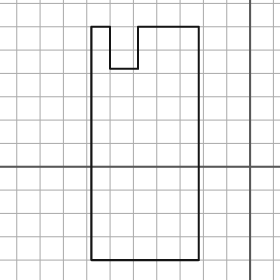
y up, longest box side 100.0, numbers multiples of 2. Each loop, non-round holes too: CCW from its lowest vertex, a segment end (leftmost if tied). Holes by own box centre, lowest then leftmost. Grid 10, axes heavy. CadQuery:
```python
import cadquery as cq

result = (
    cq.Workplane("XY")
    .moveTo(-68.0, -40.0)
    .lineTo(-22.0, -40.0)
    .lineTo(-22.0, 60.0)
    .lineTo(-48.0, 60.0)
    .lineTo(-48.0, 42.0)
    .lineTo(-60.0, 42.0)
    .lineTo(-60.0, 60.0)
    .lineTo(-68.0, 60.0)
    .close()
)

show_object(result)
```